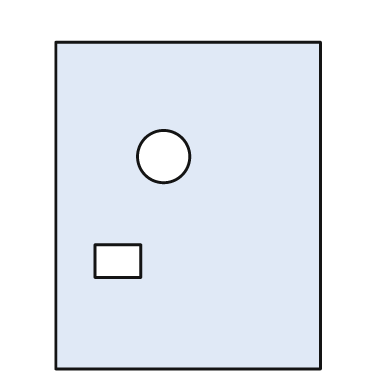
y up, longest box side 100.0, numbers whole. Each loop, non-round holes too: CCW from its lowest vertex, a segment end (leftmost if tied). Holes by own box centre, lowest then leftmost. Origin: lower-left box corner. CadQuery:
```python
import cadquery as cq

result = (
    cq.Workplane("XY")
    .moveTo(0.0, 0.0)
    .lineTo(81.0, 0.0)
    .lineTo(81.0, 100.0)
    .lineTo(0.0, 100.0)
    .close()
    .moveTo(12.0, 28.0)
    .lineTo(26.0, 28.0)
    .lineTo(26.0, 38.0)
    .lineTo(12.0, 38.0)
    .close()
    .moveTo(33.0, 65.0)
    .circle(8.0)
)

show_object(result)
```